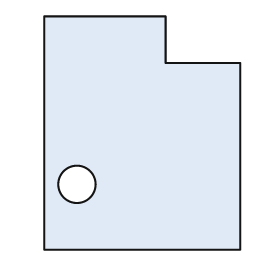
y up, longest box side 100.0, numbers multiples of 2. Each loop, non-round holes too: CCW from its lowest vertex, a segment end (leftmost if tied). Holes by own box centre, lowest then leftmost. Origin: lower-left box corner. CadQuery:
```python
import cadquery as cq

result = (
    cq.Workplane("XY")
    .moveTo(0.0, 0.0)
    .lineTo(84.0, 0.0)
    .lineTo(84.0, 80.0)
    .lineTo(52.0, 80.0)
    .lineTo(52.0, 100.0)
    .lineTo(0.0, 100.0)
    .close()
    .moveTo(14.0, 28.0)
    .circle(8.0)
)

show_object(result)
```